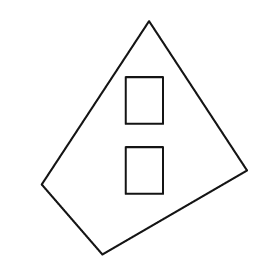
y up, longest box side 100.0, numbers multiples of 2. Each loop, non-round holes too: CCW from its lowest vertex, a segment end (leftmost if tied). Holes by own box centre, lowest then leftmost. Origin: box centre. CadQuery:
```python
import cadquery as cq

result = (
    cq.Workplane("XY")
    .moveTo(-18.0, -50.0)
    .lineTo(44.0, -14.0)
    .lineTo(2.0, 50.0)
    .lineTo(-44.0, -20.0)
    .close()
    .moveTo(-8.0, -24.0)
    .lineTo(8.0, -24.0)
    .lineTo(8.0, -4.0)
    .lineTo(-8.0, -4.0)
    .close()
    .moveTo(-8.0, 6.0)
    .lineTo(8.0, 6.0)
    .lineTo(8.0, 26.0)
    .lineTo(-8.0, 26.0)
    .close()
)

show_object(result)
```